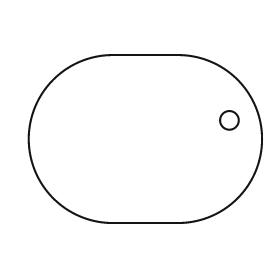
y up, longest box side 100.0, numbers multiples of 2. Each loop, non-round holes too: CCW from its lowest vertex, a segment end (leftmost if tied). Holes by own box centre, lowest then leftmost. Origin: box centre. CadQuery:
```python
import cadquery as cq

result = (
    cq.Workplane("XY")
    .moveTo(-14.0, -36.0)
    .lineTo(14.0, -36.0)
    .threePointArc((50.0, 0.0), (14.0, 36.0))
    .lineTo(-14.0, 36.0)
    .threePointArc((-50.0, 0.0), (-14.0, -36.0))
    .close()
    .moveTo(36.0, 8.0)
    .circle(4.0)
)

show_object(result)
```